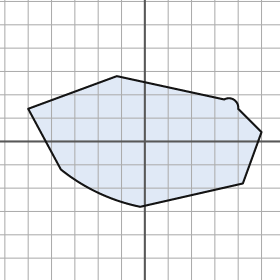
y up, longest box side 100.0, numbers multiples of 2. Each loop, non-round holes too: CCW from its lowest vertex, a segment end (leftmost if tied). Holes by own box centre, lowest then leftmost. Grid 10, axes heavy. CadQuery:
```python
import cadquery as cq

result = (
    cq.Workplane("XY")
    .moveTo(-2.0, -28.0)
    .lineTo(42.0, -18.0)
    .lineTo(50.0, 4.0)
    .lineTo(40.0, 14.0)
    .threePointArc((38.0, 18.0), (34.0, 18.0))
    .lineTo(-12.0, 28.0)
    .lineTo(-50.0, 14.0)
    .lineTo(-36.0, -12.0)
    .threePointArc((-20.0, -22.0), (-2.0, -28.0))
    .close()
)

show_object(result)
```